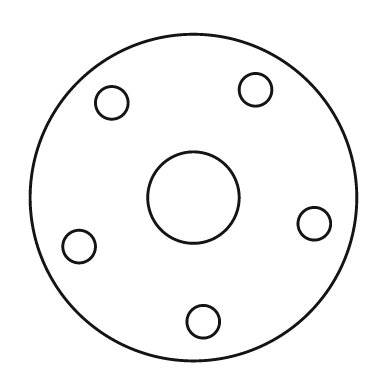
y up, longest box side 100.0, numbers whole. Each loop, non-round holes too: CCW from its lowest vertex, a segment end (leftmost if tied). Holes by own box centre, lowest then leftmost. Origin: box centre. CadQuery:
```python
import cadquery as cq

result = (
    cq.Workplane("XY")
    .moveTo(0.0, 0.0)
    .circle(50.0)
    .moveTo(3.0, -38.0)
    .circle(5.0)
    .moveTo(-35.0, -15.0)
    .circle(5.0)
    .moveTo(37.0, -8.0)
    .circle(5.0)
    .moveTo(0.0, 0.0)
    .circle(14.0)
    .moveTo(-25.0, 29.0)
    .circle(5.0)
    .moveTo(19.0, 33.0)
    .circle(5.0)
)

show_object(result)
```